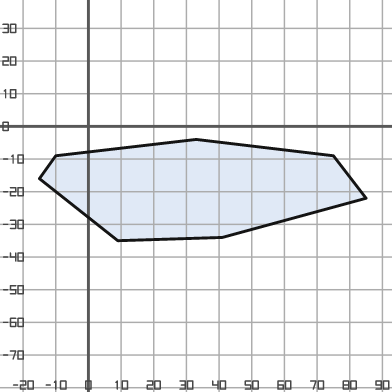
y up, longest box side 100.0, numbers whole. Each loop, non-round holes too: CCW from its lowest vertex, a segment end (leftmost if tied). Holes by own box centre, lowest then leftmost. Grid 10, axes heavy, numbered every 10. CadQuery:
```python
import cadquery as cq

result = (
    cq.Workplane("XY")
    .moveTo(9.0, -35.0)
    .lineTo(41.0, -34.0)
    .lineTo(85.0, -22.0)
    .lineTo(75.0, -9.0)
    .lineTo(33.0, -4.0)
    .lineTo(-10.0, -9.0)
    .lineTo(-15.0, -16.0)
    .close()
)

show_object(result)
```